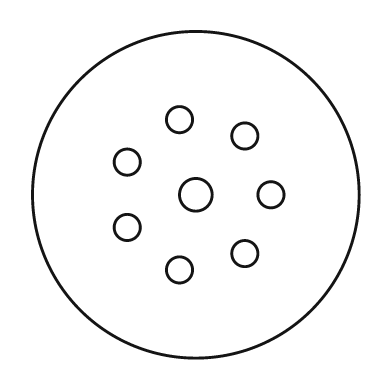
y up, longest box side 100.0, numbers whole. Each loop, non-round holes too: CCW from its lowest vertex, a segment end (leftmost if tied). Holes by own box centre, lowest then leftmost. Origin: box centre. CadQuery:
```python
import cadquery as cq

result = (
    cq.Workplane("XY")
    .moveTo(0.0, 0.0)
    .circle(50.0)
    .moveTo(-5.0, -23.0)
    .circle(4.0)
    .moveTo(15.0, -18.0)
    .circle(4.0)
    .moveTo(-21.0, -10.0)
    .circle(4.0)
    .moveTo(0.0, 0.0)
    .circle(5.0)
    .moveTo(23.0, 0.0)
    .circle(4.0)
    .moveTo(-21.0, 10.0)
    .circle(4.0)
    .moveTo(15.0, 18.0)
    .circle(4.0)
    .moveTo(-5.0, 23.0)
    .circle(4.0)
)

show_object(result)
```